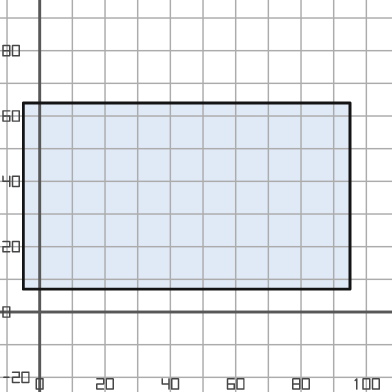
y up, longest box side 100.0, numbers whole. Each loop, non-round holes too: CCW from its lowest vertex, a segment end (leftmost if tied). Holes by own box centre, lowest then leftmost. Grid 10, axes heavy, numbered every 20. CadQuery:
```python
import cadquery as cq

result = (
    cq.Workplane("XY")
    .moveTo(-5.0, 7.0)
    .lineTo(95.0, 7.0)
    .lineTo(95.0, 64.0)
    .lineTo(-5.0, 64.0)
    .close()
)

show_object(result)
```